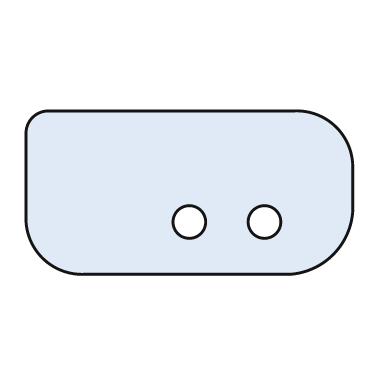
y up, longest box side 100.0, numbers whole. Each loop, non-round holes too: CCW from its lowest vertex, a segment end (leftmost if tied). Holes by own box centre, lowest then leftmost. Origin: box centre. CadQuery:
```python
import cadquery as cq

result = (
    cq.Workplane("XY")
    .moveTo(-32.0, -25.0)
    .lineTo(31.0, -25.0)
    .threePointArc((44.0, -19.0), (50.0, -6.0))
    .lineTo(50.0, 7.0)
    .threePointArc((45.0, 20.0), (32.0, 25.0))
    .lineTo(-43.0, 25.0)
    .threePointArc((-48.0, 23.0), (-50.0, 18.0))
    .lineTo(-50.0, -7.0)
    .threePointArc((-45.0, -20.0), (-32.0, -25.0))
    .close()
    .moveTo(0.0, -9.0)
    .circle(5.0)
    .moveTo(23.0, -9.0)
    .circle(5.0)
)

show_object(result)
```